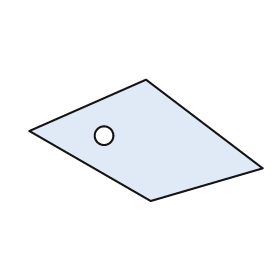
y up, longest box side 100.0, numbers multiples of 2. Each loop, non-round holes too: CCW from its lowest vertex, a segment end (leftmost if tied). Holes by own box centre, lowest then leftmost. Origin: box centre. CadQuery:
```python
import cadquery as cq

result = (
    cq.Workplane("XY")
    .moveTo(2.0, -26.0)
    .lineTo(50.0, -12.0)
    .lineTo(0.0, 26.0)
    .lineTo(-50.0, 4.0)
    .close()
    .moveTo(-18.0, 2.0)
    .circle(4.0)
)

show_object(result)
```